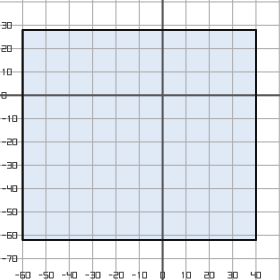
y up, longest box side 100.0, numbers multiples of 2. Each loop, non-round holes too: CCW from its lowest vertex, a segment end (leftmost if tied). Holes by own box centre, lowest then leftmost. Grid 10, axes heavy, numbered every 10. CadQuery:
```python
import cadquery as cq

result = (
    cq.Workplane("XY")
    .moveTo(-60.0, -62.0)
    .lineTo(40.0, -62.0)
    .lineTo(40.0, 28.0)
    .lineTo(-60.0, 28.0)
    .close()
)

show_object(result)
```